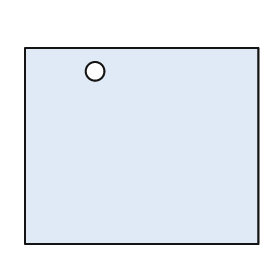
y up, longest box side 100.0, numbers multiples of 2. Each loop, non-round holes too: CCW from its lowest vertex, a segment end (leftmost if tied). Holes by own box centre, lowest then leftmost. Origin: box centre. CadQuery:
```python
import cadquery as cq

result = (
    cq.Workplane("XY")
    .moveTo(-50.0, -42.0)
    .lineTo(50.0, -42.0)
    .lineTo(50.0, 42.0)
    .lineTo(-50.0, 42.0)
    .close()
    .moveTo(-20.0, 32.0)
    .circle(4.0)
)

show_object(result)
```